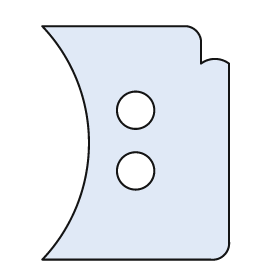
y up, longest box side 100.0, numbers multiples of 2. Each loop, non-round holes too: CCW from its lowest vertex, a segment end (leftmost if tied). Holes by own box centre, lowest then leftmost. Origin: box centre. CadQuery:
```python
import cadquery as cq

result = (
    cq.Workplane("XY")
    .moveTo(-40.0, -50.0)
    .lineTo(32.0, -50.0)
    .threePointArc((38.0, -48.0), (40.0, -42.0))
    .lineTo(40.0, 34.0)
    .threePointArc((34.0, 36.0), (28.0, 34.0))
    .lineTo(28.0, 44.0)
    .threePointArc((26.0, 48.0), (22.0, 50.0))
    .lineTo(-40.0, 50.0)
    .threePointArc((-20.0, 0.0), (-40.0, -50.0))
    .close()
    .moveTo(0.0, -12.0)
    .circle(8.0)
    .moveTo(0.0, 14.0)
    .circle(8.0)
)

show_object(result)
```